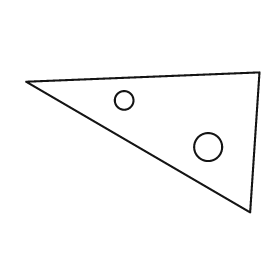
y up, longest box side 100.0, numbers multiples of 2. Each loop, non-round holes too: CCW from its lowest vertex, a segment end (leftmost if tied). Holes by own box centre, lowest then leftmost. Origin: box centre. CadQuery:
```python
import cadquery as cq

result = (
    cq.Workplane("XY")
    .moveTo(46.0, -30.0)
    .lineTo(50.0, 30.0)
    .lineTo(-50.0, 26.0)
    .close()
    .moveTo(28.0, -2.0)
    .circle(6.0)
    .moveTo(-8.0, 18.0)
    .circle(4.0)
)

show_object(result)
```